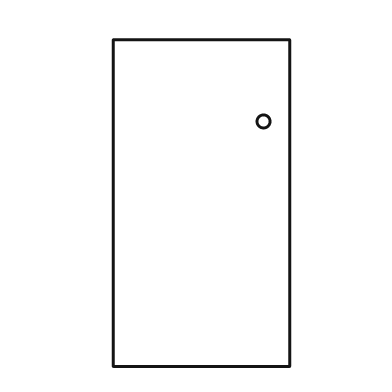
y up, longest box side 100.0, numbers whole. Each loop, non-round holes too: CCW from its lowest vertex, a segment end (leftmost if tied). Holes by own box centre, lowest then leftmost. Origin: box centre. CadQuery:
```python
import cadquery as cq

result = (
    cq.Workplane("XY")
    .moveTo(-27.0, -50.0)
    .lineTo(27.0, -50.0)
    .lineTo(27.0, 50.0)
    .lineTo(-27.0, 50.0)
    .close()
    .moveTo(19.0, 25.0)
    .circle(2.0)
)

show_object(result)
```